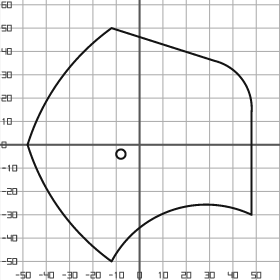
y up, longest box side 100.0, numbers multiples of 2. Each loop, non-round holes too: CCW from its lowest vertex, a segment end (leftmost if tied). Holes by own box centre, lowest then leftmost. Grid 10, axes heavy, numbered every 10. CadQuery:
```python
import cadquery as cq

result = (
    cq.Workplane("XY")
    .moveTo(-12.0, -50.0)
    .threePointArc((14.0, -28.0), (48.0, -30.0))
    .lineTo(48.0, 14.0)
    .threePointArc((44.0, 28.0), (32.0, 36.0))
    .lineTo(-12.0, 50.0)
    .threePointArc((-34.0, 28.0), (-48.0, 0.0))
    .threePointArc((-34.0, -28.0), (-12.0, -50.0))
    .close()
    .moveTo(-8.0, -4.0)
    .circle(2.0)
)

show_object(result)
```